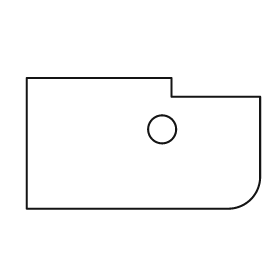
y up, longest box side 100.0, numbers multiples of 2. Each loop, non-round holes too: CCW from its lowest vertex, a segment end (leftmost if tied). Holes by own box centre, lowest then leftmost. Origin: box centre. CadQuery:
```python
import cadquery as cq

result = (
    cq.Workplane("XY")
    .moveTo(-50.0, -28.0)
    .lineTo(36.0, -28.0)
    .threePointArc((46.0, -24.0), (50.0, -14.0))
    .lineTo(50.0, 20.0)
    .lineTo(12.0, 20.0)
    .lineTo(12.0, 28.0)
    .lineTo(-50.0, 28.0)
    .close()
    .moveTo(8.0, 6.0)
    .circle(6.0)
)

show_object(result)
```